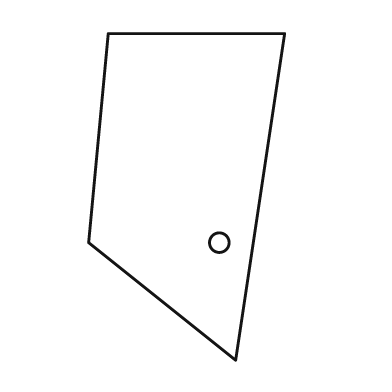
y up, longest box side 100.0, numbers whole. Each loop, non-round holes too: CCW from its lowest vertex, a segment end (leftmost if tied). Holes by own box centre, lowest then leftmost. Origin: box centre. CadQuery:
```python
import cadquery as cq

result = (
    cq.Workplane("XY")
    .moveTo(15.0, -50.0)
    .lineTo(30.0, 50.0)
    .lineTo(-24.0, 50.0)
    .lineTo(-30.0, -14.0)
    .close()
    .moveTo(10.0, -14.0)
    .circle(3.0)
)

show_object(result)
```